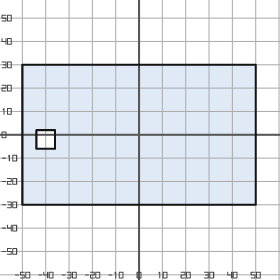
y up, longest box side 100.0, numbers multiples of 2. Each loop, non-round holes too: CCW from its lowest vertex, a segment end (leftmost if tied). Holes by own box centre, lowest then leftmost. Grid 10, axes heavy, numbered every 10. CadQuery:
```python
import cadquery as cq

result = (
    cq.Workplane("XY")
    .moveTo(-50.0, -30.0)
    .lineTo(50.0, -30.0)
    .lineTo(50.0, 30.0)
    .lineTo(-50.0, 30.0)
    .close()
    .moveTo(-44.0, -6.0)
    .lineTo(-36.0, -6.0)
    .lineTo(-36.0, 2.0)
    .lineTo(-44.0, 2.0)
    .close()
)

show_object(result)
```